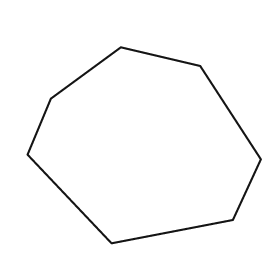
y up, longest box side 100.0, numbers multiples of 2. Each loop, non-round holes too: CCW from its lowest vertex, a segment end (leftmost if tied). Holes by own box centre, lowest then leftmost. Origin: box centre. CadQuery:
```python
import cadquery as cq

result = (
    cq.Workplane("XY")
    .moveTo(-14.0, -42.0)
    .lineTo(38.0, -32.0)
    .lineTo(50.0, -6.0)
    .lineTo(24.0, 34.0)
    .lineTo(-10.0, 42.0)
    .lineTo(-40.0, 20.0)
    .lineTo(-50.0, -4.0)
    .close()
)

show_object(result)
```